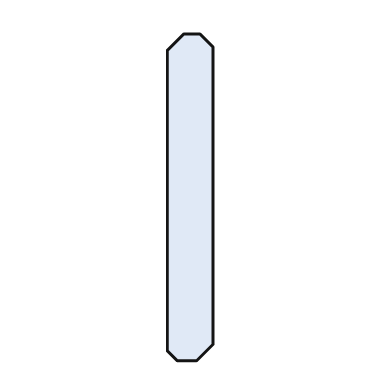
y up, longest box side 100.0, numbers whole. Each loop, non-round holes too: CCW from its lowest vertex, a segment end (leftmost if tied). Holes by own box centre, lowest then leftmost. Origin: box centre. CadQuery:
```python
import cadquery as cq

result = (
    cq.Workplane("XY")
    .moveTo(-4.0, -50.0)
    .lineTo(2.0, -50.0)
    .lineTo(7.0, -45.0)
    .lineTo(7.0, 46.0)
    .lineTo(3.0, 50.0)
    .lineTo(-2.0, 50.0)
    .lineTo(-7.0, 45.0)
    .lineTo(-7.0, -47.0)
    .close()
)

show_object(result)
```